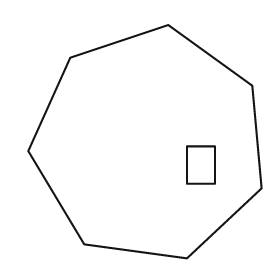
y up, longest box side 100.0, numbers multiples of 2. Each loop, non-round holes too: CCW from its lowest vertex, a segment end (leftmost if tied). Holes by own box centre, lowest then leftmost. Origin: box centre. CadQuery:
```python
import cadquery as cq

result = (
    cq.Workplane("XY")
    .moveTo(18.0, -50.0)
    .lineTo(50.0, -20.0)
    .lineTo(46.0, 24.0)
    .lineTo(10.0, 50.0)
    .lineTo(-32.0, 36.0)
    .lineTo(-50.0, -4.0)
    .lineTo(-26.0, -44.0)
    .close()
    .moveTo(18.0, -18.0)
    .lineTo(30.0, -18.0)
    .lineTo(30.0, -2.0)
    .lineTo(18.0, -2.0)
    .close()
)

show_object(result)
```